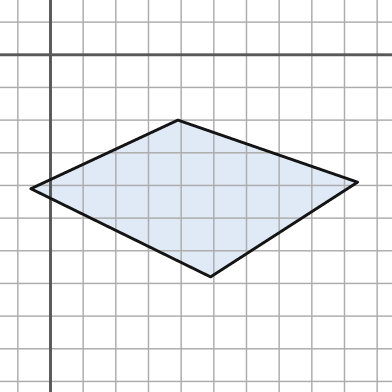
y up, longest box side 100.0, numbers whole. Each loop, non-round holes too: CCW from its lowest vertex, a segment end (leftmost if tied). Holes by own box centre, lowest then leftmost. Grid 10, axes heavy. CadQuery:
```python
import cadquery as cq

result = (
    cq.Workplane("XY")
    .moveTo(49.0, -68.0)
    .lineTo(94.0, -39.0)
    .lineTo(39.0, -20.0)
    .lineTo(-6.0, -41.0)
    .close()
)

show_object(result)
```